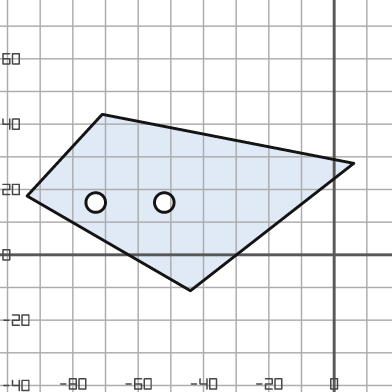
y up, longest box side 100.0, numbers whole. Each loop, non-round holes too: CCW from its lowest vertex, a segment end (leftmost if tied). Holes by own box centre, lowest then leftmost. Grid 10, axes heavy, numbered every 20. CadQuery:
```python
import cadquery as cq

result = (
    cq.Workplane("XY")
    .moveTo(-44.0, -11.0)
    .lineTo(6.0, 28.0)
    .lineTo(-71.0, 43.0)
    .lineTo(-94.0, 18.0)
    .close()
    .moveTo(-73.0, 16.0)
    .circle(3.0)
    .moveTo(-52.0, 16.0)
    .circle(3.0)
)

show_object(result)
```